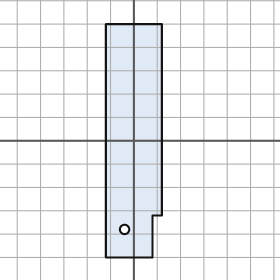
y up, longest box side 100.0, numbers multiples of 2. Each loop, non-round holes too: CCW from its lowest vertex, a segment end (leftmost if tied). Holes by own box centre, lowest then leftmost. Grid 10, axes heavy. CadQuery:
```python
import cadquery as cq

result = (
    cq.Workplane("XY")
    .moveTo(-12.0, -50.0)
    .lineTo(8.0, -50.0)
    .lineTo(8.0, -32.0)
    .lineTo(12.0, -32.0)
    .lineTo(12.0, 50.0)
    .lineTo(-12.0, 50.0)
    .close()
    .moveTo(-4.0, -38.0)
    .circle(2.0)
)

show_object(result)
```